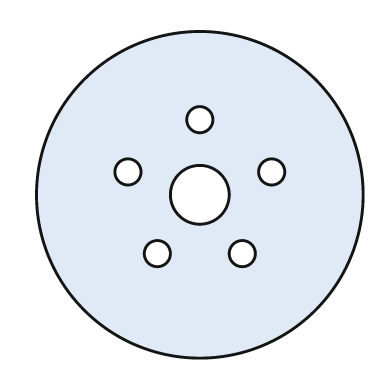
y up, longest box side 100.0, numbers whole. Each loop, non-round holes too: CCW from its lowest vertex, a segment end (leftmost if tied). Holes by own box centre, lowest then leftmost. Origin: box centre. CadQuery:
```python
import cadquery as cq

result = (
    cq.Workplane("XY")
    .moveTo(0.0, 0.0)
    .circle(50.0)
    .moveTo(-13.0, -18.0)
    .circle(4.0)
    .moveTo(13.0, -18.0)
    .circle(4.0)
    .moveTo(0.0, 0.0)
    .circle(9.0)
    .moveTo(-22.0, 7.0)
    .circle(4.0)
    .moveTo(22.0, 7.0)
    .circle(4.0)
    .moveTo(0.0, 23.0)
    .circle(4.0)
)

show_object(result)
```